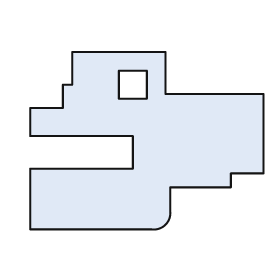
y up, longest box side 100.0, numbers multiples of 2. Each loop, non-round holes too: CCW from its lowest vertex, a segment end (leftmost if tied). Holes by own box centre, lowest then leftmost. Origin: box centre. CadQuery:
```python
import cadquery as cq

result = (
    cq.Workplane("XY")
    .moveTo(-50.0, -38.0)
    .lineTo(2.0, -38.0)
    .threePointArc((8.0, -36.0), (10.0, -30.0))
    .lineTo(10.0, -20.0)
    .lineTo(36.0, -20.0)
    .lineTo(36.0, -14.0)
    .lineTo(50.0, -14.0)
    .lineTo(50.0, 20.0)
    .lineTo(8.0, 20.0)
    .lineTo(8.0, 38.0)
    .lineTo(-32.0, 38.0)
    .lineTo(-32.0, 24.0)
    .lineTo(-36.0, 24.0)
    .lineTo(-36.0, 14.0)
    .lineTo(-50.0, 14.0)
    .lineTo(-50.0, 2.0)
    .lineTo(-6.0, 2.0)
    .lineTo(-6.0, -12.0)
    .lineTo(-50.0, -12.0)
    .close()
    .moveTo(-12.0, 18.0)
    .lineTo(0.0, 18.0)
    .lineTo(0.0, 30.0)
    .lineTo(-12.0, 30.0)
    .close()
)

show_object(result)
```